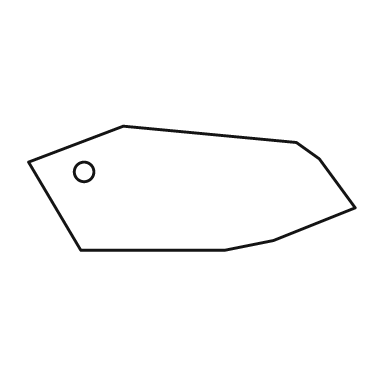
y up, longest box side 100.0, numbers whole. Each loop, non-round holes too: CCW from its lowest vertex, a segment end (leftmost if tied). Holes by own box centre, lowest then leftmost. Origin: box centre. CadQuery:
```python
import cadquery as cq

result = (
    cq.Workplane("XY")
    .moveTo(-34.0, -19.0)
    .lineTo(10.0, -19.0)
    .lineTo(25.0, -16.0)
    .lineTo(50.0, -6.0)
    .lineTo(39.0, 9.0)
    .lineTo(32.0, 14.0)
    .lineTo(-21.0, 19.0)
    .lineTo(-50.0, 8.0)
    .close()
    .moveTo(-33.0, 5.0)
    .circle(3.0)
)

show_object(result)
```